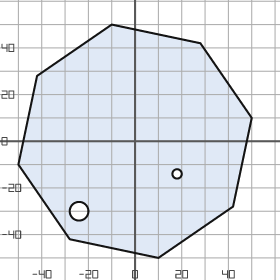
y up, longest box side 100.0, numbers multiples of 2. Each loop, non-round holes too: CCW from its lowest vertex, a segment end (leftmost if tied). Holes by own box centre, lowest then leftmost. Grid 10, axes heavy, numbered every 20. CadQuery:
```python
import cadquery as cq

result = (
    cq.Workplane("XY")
    .moveTo(10.0, -50.0)
    .lineTo(42.0, -28.0)
    .lineTo(50.0, 10.0)
    .lineTo(28.0, 42.0)
    .lineTo(-10.0, 50.0)
    .lineTo(-42.0, 28.0)
    .lineTo(-50.0, -10.0)
    .lineTo(-28.0, -42.0)
    .close()
    .moveTo(-24.0, -30.0)
    .circle(4.0)
    .moveTo(18.0, -14.0)
    .circle(2.0)
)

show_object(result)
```